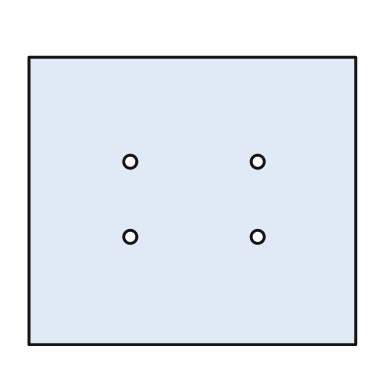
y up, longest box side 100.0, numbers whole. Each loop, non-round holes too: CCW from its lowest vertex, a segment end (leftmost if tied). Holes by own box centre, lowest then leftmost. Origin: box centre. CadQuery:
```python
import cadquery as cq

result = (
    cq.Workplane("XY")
    .moveTo(-50.0, -44.0)
    .lineTo(50.0, -44.0)
    .lineTo(50.0, 44.0)
    .lineTo(-50.0, 44.0)
    .close()
    .moveTo(-19.0, -11.0)
    .circle(2.0)
    .moveTo(20.0, -11.0)
    .circle(2.0)
    .moveTo(-19.0, 12.0)
    .circle(2.0)
    .moveTo(20.0, 12.0)
    .circle(2.0)
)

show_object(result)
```